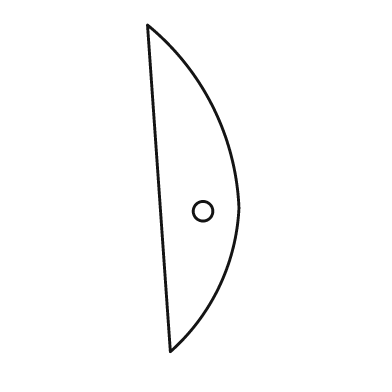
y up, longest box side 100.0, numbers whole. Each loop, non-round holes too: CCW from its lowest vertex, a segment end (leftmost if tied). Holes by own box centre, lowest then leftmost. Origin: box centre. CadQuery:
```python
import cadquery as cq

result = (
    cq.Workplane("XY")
    .moveTo(-7.0, -50.0)
    .threePointArc((8.0, -30.0), (14.0, -6.0))
    .threePointArc((6.0, 25.0), (-14.0, 50.0))
    .close()
    .moveTo(3.0, -7.0)
    .circle(3.0)
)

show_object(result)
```